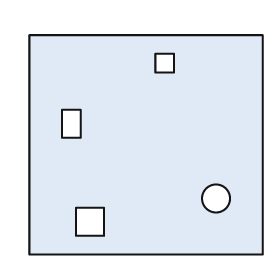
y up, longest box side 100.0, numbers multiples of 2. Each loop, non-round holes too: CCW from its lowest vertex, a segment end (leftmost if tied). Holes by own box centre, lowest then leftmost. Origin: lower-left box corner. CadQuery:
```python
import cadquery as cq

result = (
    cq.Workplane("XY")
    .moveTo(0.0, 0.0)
    .lineTo(100.0, 0.0)
    .lineTo(100.0, 94.0)
    .lineTo(0.0, 94.0)
    .close()
    .moveTo(20.0, 8.0)
    .lineTo(32.0, 8.0)
    .lineTo(32.0, 20.0)
    .lineTo(20.0, 20.0)
    .close()
    .moveTo(80.0, 24.0)
    .circle(6.0)
    .moveTo(14.0, 50.0)
    .lineTo(22.0, 50.0)
    .lineTo(22.0, 62.0)
    .lineTo(14.0, 62.0)
    .close()
    .moveTo(54.0, 78.0)
    .lineTo(62.0, 78.0)
    .lineTo(62.0, 86.0)
    .lineTo(54.0, 86.0)
    .close()
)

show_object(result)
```